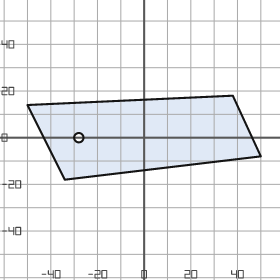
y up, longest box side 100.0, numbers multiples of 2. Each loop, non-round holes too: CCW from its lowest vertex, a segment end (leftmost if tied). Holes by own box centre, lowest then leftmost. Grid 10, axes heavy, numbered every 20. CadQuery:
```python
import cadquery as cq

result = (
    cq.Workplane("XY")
    .moveTo(-34.0, -18.0)
    .lineTo(50.0, -8.0)
    .lineTo(38.0, 18.0)
    .lineTo(-50.0, 14.0)
    .close()
    .moveTo(-28.0, 0.0)
    .circle(2.0)
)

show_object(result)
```